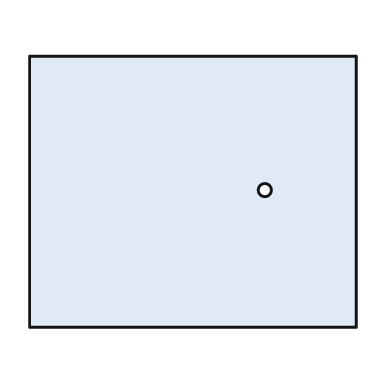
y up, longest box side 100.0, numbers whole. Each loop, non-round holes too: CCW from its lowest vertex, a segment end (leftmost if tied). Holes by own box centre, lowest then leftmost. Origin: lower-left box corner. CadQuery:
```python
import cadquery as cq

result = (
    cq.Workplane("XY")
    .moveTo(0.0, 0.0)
    .lineTo(100.0, 0.0)
    .lineTo(100.0, 83.0)
    .lineTo(0.0, 83.0)
    .close()
    .moveTo(72.0, 42.0)
    .circle(2.0)
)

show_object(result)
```